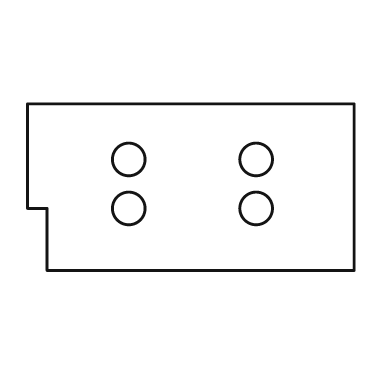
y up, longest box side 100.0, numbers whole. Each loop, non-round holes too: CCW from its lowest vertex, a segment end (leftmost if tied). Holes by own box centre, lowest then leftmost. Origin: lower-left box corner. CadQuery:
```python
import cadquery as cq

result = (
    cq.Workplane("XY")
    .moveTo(6.0, 0.0)
    .lineTo(100.0, 0.0)
    .lineTo(100.0, 51.0)
    .lineTo(0.0, 51.0)
    .lineTo(0.0, 19.0)
    .lineTo(6.0, 19.0)
    .close()
    .moveTo(31.0, 19.0)
    .circle(5.0)
    .moveTo(70.0, 19.0)
    .circle(5.0)
    .moveTo(31.0, 34.0)
    .circle(5.0)
    .moveTo(70.0, 34.0)
    .circle(5.0)
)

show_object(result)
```